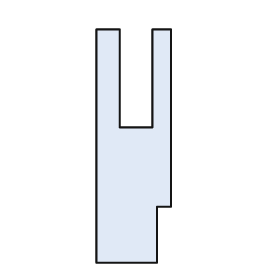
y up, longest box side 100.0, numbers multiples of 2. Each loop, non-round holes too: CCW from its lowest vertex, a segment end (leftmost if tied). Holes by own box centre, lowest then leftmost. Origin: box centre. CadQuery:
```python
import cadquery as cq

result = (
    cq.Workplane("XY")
    .moveTo(-16.0, -50.0)
    .lineTo(10.0, -50.0)
    .lineTo(10.0, -26.0)
    .lineTo(16.0, -26.0)
    .lineTo(16.0, 50.0)
    .lineTo(8.0, 50.0)
    .lineTo(8.0, 8.0)
    .lineTo(-6.0, 8.0)
    .lineTo(-6.0, 50.0)
    .lineTo(-16.0, 50.0)
    .close()
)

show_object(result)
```